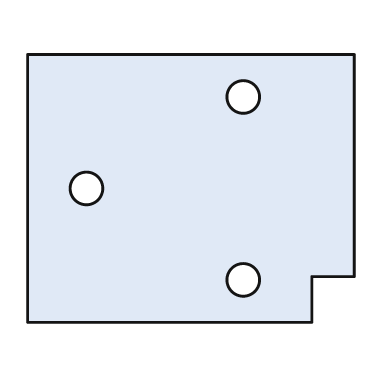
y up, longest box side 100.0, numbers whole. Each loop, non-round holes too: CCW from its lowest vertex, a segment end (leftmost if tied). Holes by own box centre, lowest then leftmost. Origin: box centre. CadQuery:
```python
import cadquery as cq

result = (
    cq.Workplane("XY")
    .moveTo(-50.0, -41.0)
    .lineTo(37.0, -41.0)
    .lineTo(37.0, -27.0)
    .lineTo(50.0, -27.0)
    .lineTo(50.0, 41.0)
    .lineTo(-50.0, 41.0)
    .close()
    .moveTo(16.0, -28.0)
    .circle(5.0)
    .moveTo(-32.0, 0.0)
    .circle(5.0)
    .moveTo(16.0, 28.0)
    .circle(5.0)
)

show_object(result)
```